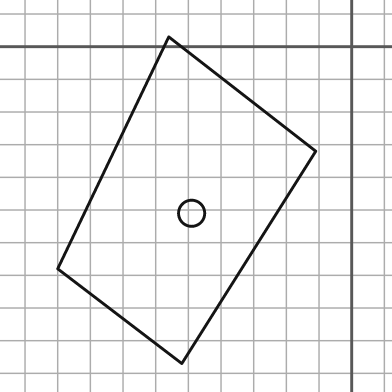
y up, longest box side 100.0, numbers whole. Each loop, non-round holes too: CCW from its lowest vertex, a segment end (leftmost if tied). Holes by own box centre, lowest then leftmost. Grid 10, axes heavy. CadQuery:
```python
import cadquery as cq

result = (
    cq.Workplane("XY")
    .moveTo(-52.0, -97.0)
    .lineTo(-11.0, -32.0)
    .lineTo(-56.0, 3.0)
    .lineTo(-90.0, -68.0)
    .close()
    .moveTo(-49.0, -51.0)
    .circle(4.0)
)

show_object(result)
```